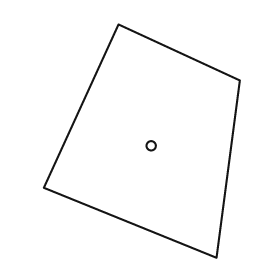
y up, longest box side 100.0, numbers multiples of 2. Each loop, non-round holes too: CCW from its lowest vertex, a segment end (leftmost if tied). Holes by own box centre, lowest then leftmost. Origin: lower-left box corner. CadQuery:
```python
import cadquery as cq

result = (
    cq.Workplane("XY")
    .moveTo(74.0, 0.0)
    .lineTo(84.0, 76.0)
    .lineTo(32.0, 100.0)
    .lineTo(0.0, 30.0)
    .close()
    .moveTo(46.0, 48.0)
    .circle(2.0)
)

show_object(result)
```